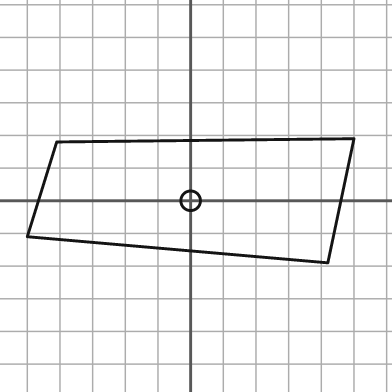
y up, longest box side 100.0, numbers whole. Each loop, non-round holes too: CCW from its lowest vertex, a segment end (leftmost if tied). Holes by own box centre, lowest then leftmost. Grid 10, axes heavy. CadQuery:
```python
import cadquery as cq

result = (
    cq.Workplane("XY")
    .moveTo(42.0, -19.0)
    .lineTo(50.0, 19.0)
    .lineTo(-41.0, 18.0)
    .lineTo(-50.0, -11.0)
    .close()
    .moveTo(0.0, 0.0)
    .circle(3.0)
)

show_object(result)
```